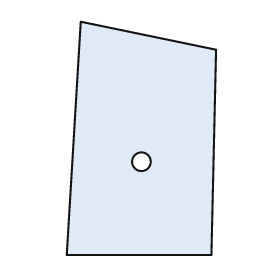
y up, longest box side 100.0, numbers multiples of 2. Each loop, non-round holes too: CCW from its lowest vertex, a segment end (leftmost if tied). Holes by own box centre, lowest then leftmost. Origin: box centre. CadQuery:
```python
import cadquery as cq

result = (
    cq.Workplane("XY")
    .moveTo(-32.0, -50.0)
    .lineTo(30.0, -50.0)
    .lineTo(32.0, 38.0)
    .lineTo(-26.0, 50.0)
    .close()
    .moveTo(0.0, -10.0)
    .circle(4.0)
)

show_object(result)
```